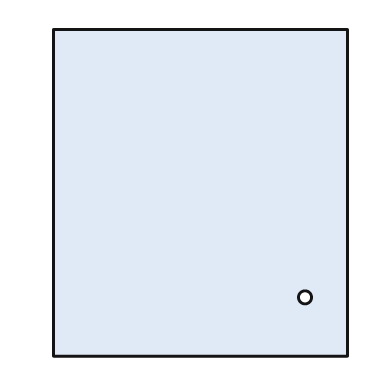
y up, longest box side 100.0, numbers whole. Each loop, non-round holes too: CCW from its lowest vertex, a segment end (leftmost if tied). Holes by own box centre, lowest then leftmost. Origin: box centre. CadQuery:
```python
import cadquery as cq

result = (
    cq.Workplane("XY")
    .moveTo(-45.0, -50.0)
    .lineTo(45.0, -50.0)
    .lineTo(45.0, 50.0)
    .lineTo(-45.0, 50.0)
    .close()
    .moveTo(32.0, -32.0)
    .circle(2.0)
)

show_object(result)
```